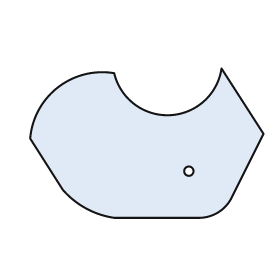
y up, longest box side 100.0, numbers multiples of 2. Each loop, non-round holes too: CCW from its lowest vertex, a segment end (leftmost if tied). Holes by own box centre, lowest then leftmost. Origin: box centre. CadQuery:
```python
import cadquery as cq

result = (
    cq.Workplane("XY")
    .moveTo(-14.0, -32.0)
    .lineTo(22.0, -32.0)
    .threePointArc((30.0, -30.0), (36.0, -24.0))
    .lineTo(50.0, 4.0)
    .lineTo(32.0, 32.0)
    .threePointArc((10.0, 12.0), (-14.0, 30.0))
    .threePointArc((-38.0, 24.0), (-50.0, 2.0))
    .lineTo(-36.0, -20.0)
    .threePointArc((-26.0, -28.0), (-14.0, -32.0))
    .close()
    .moveTo(18.0, -12.0)
    .circle(2.0)
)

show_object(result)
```